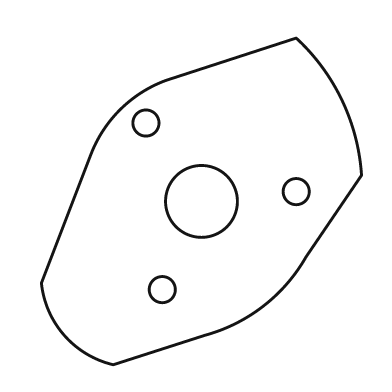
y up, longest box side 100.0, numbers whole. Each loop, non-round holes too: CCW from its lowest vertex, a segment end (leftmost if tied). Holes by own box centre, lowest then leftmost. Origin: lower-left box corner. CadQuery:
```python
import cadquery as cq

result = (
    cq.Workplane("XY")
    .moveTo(22.0, 0.0)
    .lineTo(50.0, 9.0)
    .threePointArc((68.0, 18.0), (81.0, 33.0))
    .lineTo(98.0, 58.0)
    .threePointArc((92.0, 81.0), (78.0, 100.0))
    .lineTo(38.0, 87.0)
    .threePointArc((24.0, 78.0), (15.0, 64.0))
    .lineTo(0.0, 25.0)
    .threePointArc((7.0, 9.0), (22.0, 0.0))
    .close()
    .moveTo(37.0, 23.0)
    .circle(4.0)
    .moveTo(49.0, 50.0)
    .circle(11.0)
    .moveTo(78.0, 53.0)
    .circle(4.0)
    .moveTo(32.0, 74.0)
    .circle(4.0)
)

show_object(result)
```